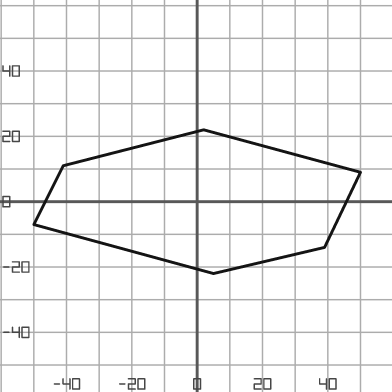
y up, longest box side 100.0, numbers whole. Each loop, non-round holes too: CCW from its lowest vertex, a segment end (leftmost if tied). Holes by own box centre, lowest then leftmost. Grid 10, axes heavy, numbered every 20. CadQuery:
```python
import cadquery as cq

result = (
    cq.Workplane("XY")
    .moveTo(5.0, -22.0)
    .lineTo(39.0, -14.0)
    .lineTo(50.0, 9.0)
    .lineTo(2.0, 22.0)
    .lineTo(-41.0, 11.0)
    .lineTo(-50.0, -7.0)
    .close()
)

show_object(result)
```